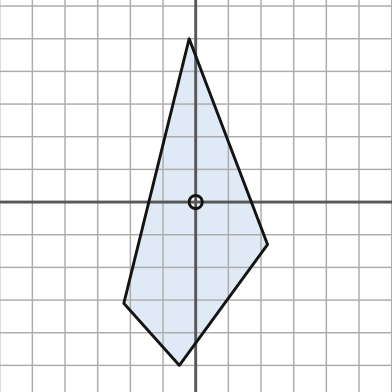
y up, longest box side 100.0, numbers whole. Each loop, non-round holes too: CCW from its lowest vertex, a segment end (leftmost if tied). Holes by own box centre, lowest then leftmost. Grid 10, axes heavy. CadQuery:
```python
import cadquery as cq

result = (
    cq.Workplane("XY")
    .moveTo(-5.0, -50.0)
    .lineTo(22.0, -13.0)
    .lineTo(-2.0, 50.0)
    .lineTo(-22.0, -31.0)
    .close()
    .moveTo(0.0, 0.0)
    .circle(2.0)
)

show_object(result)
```